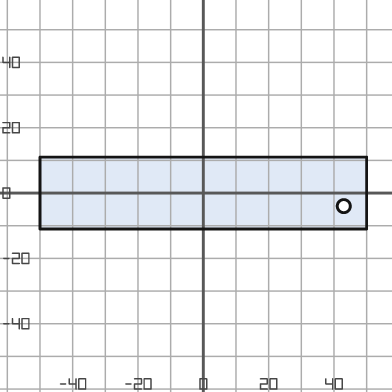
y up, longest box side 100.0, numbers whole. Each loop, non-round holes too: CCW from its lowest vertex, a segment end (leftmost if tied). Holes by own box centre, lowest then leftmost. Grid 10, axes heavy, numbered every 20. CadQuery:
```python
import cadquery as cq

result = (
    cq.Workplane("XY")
    .moveTo(-50.0, -11.0)
    .lineTo(50.0, -11.0)
    .lineTo(50.0, 11.0)
    .lineTo(-50.0, 11.0)
    .close()
    .moveTo(43.0, -4.0)
    .circle(2.0)
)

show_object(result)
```